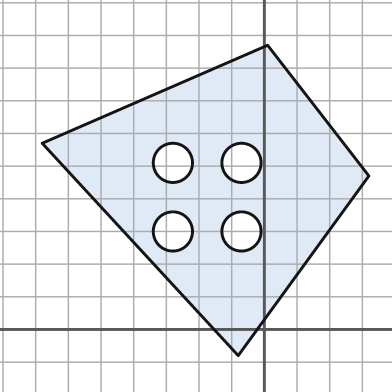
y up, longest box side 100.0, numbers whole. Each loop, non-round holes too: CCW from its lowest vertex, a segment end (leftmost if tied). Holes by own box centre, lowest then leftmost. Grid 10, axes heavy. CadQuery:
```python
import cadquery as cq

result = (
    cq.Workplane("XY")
    .moveTo(-8.0, -8.0)
    .lineTo(32.0, 47.0)
    .lineTo(1.0, 87.0)
    .lineTo(-68.0, 57.0)
    .close()
    .moveTo(-28.0, 30.0)
    .circle(6.0)
    .moveTo(-7.0, 30.0)
    .circle(6.0)
    .moveTo(-28.0, 51.0)
    .circle(6.0)
    .moveTo(-7.0, 51.0)
    .circle(6.0)
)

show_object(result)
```